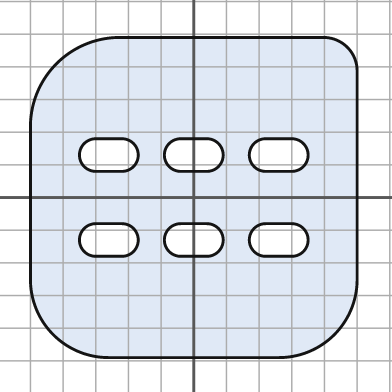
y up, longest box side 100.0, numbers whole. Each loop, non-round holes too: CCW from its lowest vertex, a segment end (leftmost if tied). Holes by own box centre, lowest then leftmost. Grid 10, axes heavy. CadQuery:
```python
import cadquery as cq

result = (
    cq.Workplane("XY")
    .moveTo(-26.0, -49.0)
    .lineTo(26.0, -49.0)
    .threePointArc((43.0, -42.0), (50.0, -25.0))
    .lineTo(50.0, 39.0)
    .threePointArc((47.0, 46.0), (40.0, 49.0))
    .lineTo(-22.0, 49.0)
    .threePointArc((-42.0, 41.0), (-50.0, 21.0))
    .lineTo(-50.0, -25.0)
    .threePointArc((-43.0, -42.0), (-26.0, -49.0))
    .close()
    .moveTo(-30.0, -18.0)
    .lineTo(-22.0, -18.0)
    .threePointArc((-17.0, -13.0), (-22.0, -8.0))
    .lineTo(-30.0, -8.0)
    .threePointArc((-35.0, -13.0), (-30.0, -18.0))
    .close()
    .moveTo(-4.0, -18.0)
    .lineTo(4.0, -18.0)
    .threePointArc((9.0, -13.0), (4.0, -8.0))
    .lineTo(-4.0, -8.0)
    .threePointArc((-9.0, -13.0), (-4.0, -18.0))
    .close()
    .moveTo(22.0, -18.0)
    .lineTo(30.0, -18.0)
    .threePointArc((35.0, -13.0), (30.0, -8.0))
    .lineTo(22.0, -8.0)
    .threePointArc((17.0, -13.0), (22.0, -18.0))
    .close()
    .moveTo(-30.0, 8.0)
    .lineTo(-22.0, 8.0)
    .threePointArc((-17.0, 13.0), (-22.0, 18.0))
    .lineTo(-30.0, 18.0)
    .threePointArc((-35.0, 13.0), (-30.0, 8.0))
    .close()
    .moveTo(-4.0, 8.0)
    .lineTo(4.0, 8.0)
    .threePointArc((9.0, 13.0), (4.0, 18.0))
    .lineTo(-4.0, 18.0)
    .threePointArc((-9.0, 13.0), (-4.0, 8.0))
    .close()
    .moveTo(22.0, 8.0)
    .lineTo(30.0, 8.0)
    .threePointArc((35.0, 13.0), (30.0, 18.0))
    .lineTo(22.0, 18.0)
    .threePointArc((17.0, 13.0), (22.0, 8.0))
    .close()
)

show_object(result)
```